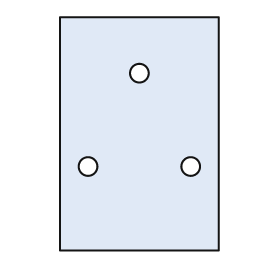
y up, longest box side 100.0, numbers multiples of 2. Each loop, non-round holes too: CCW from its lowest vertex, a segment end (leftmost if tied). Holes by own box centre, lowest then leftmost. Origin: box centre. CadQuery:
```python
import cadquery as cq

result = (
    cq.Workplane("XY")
    .moveTo(-34.0, -50.0)
    .lineTo(34.0, -50.0)
    .lineTo(34.0, 50.0)
    .lineTo(-34.0, 50.0)
    .close()
    .moveTo(-22.0, -14.0)
    .circle(4.0)
    .moveTo(22.0, -14.0)
    .circle(4.0)
    .moveTo(0.0, 26.0)
    .circle(4.0)
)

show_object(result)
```